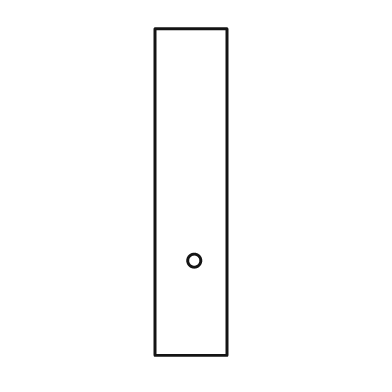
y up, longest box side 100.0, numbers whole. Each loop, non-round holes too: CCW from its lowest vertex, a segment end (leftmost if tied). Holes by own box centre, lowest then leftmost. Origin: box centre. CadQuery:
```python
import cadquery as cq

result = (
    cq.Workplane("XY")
    .moveTo(-11.0, -50.0)
    .lineTo(11.0, -50.0)
    .lineTo(11.0, 50.0)
    .lineTo(-11.0, 50.0)
    .close()
    .moveTo(1.0, -21.0)
    .circle(2.0)
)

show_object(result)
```